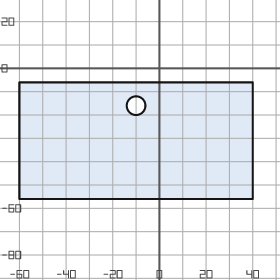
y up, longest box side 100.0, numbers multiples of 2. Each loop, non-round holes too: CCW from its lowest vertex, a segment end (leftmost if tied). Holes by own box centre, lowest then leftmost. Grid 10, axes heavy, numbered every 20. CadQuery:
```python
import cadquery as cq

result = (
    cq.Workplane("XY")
    .moveTo(-60.0, -56.0)
    .lineTo(40.0, -56.0)
    .lineTo(40.0, -6.0)
    .lineTo(-60.0, -6.0)
    .close()
    .moveTo(-10.0, -16.0)
    .circle(4.0)
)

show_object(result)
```